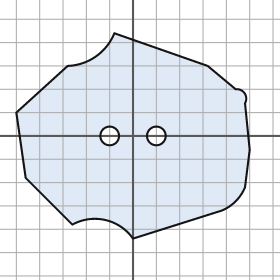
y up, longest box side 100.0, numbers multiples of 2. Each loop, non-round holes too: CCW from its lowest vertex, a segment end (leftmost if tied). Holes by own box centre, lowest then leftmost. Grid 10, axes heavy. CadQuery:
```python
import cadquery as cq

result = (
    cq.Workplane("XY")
    .moveTo(0.0, -44.0)
    .lineTo(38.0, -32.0)
    .threePointArc((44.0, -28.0), (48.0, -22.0))
    .lineTo(50.0, -6.0)
    .lineTo(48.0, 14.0)
    .threePointArc((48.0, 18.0), (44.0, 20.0))
    .lineTo(32.0, 30.0)
    .lineTo(-8.0, 44.0)
    .threePointArc((-16.0, 34.0), (-28.0, 30.0))
    .lineTo(-50.0, 10.0)
    .lineTo(-46.0, -18.0)
    .lineTo(-26.0, -38.0)
    .threePointArc((-12.0, -36.0), (0.0, -44.0))
    .close()
    .moveTo(-10.0, 0.0)
    .circle(4.0)
    .moveTo(10.0, 0.0)
    .circle(4.0)
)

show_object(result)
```